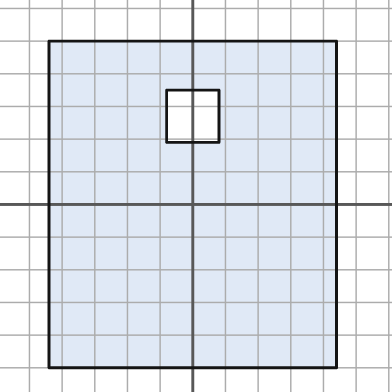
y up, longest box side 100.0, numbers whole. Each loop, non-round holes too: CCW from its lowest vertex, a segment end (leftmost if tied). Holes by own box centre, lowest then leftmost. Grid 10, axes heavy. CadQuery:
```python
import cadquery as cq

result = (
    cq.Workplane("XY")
    .moveTo(-44.0, -50.0)
    .lineTo(44.0, -50.0)
    .lineTo(44.0, 50.0)
    .lineTo(-44.0, 50.0)
    .close()
    .moveTo(-8.0, 19.0)
    .lineTo(8.0, 19.0)
    .lineTo(8.0, 35.0)
    .lineTo(-8.0, 35.0)
    .close()
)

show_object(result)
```